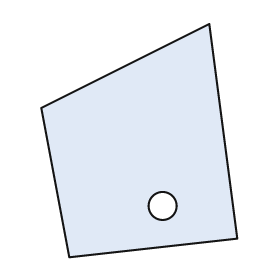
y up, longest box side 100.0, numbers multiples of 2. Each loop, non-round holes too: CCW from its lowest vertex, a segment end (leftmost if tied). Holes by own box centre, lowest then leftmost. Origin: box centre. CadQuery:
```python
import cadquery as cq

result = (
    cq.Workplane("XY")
    .moveTo(-30.0, -50.0)
    .lineTo(42.0, -42.0)
    .lineTo(30.0, 50.0)
    .lineTo(-42.0, 14.0)
    .close()
    .moveTo(10.0, -28.0)
    .circle(6.0)
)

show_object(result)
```